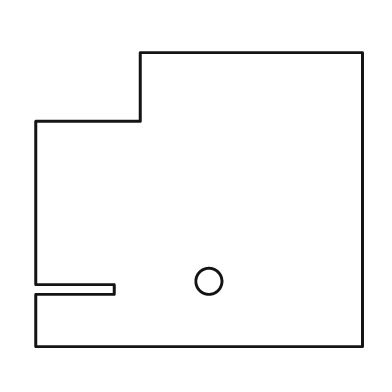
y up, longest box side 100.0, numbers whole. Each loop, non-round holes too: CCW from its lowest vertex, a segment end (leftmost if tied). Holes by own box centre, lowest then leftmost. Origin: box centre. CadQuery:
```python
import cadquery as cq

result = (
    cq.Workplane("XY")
    .moveTo(-50.0, -45.0)
    .lineTo(50.0, -45.0)
    .lineTo(50.0, 45.0)
    .lineTo(-18.0, 45.0)
    .lineTo(-18.0, 24.0)
    .lineTo(-50.0, 24.0)
    .lineTo(-50.0, -26.0)
    .lineTo(-26.0, -26.0)
    .lineTo(-26.0, -29.0)
    .lineTo(-50.0, -29.0)
    .close()
    .moveTo(3.0, -25.0)
    .circle(4.0)
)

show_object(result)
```